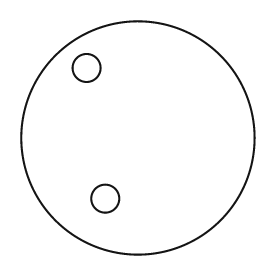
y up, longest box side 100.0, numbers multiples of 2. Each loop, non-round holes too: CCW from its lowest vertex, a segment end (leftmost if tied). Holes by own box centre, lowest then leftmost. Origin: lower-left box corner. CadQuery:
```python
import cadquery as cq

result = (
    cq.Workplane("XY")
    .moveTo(50.0, 50.0)
    .circle(50.0)
    .moveTo(36.0, 24.0)
    .circle(6.0)
    .moveTo(28.0, 80.0)
    .circle(6.0)
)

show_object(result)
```